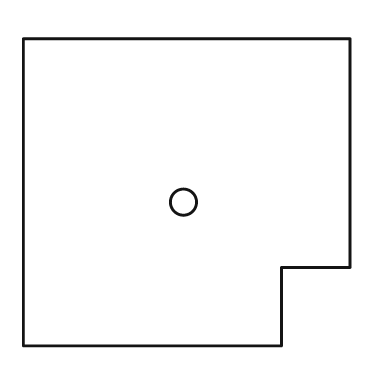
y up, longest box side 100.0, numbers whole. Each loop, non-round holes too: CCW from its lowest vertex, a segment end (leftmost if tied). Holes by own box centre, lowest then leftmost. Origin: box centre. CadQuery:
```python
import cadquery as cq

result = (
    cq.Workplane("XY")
    .moveTo(-50.0, -47.0)
    .lineTo(29.0, -47.0)
    .lineTo(29.0, -23.0)
    .lineTo(50.0, -23.0)
    .lineTo(50.0, 47.0)
    .lineTo(-50.0, 47.0)
    .close()
    .moveTo(-1.0, -3.0)
    .circle(4.0)
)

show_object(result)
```